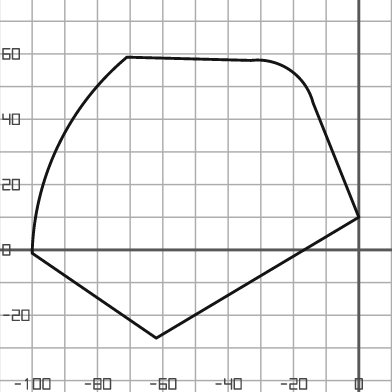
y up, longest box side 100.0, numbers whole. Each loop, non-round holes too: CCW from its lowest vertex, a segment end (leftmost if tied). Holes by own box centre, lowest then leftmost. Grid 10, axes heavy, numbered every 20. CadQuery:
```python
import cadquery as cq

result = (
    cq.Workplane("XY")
    .moveTo(-62.0, -27.0)
    .lineTo(0.0, 10.0)
    .lineTo(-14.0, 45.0)
    .threePointArc((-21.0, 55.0), (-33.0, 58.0))
    .lineTo(-71.0, 59.0)
    .threePointArc((-92.0, 32.0), (-100.0, -1.0))
    .close()
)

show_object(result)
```